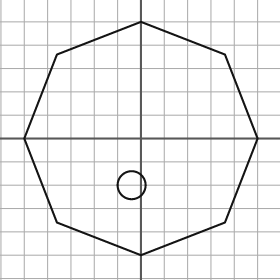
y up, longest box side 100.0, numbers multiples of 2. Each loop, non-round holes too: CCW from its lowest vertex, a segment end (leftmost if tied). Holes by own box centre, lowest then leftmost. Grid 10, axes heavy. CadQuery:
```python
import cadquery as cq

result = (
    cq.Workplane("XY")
    .moveTo(0.0, -50.0)
    .lineTo(36.0, -36.0)
    .lineTo(50.0, 0.0)
    .lineTo(36.0, 36.0)
    .lineTo(0.0, 50.0)
    .lineTo(-36.0, 36.0)
    .lineTo(-50.0, 0.0)
    .lineTo(-36.0, -36.0)
    .close()
    .moveTo(-4.0, -20.0)
    .circle(6.0)
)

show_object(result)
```